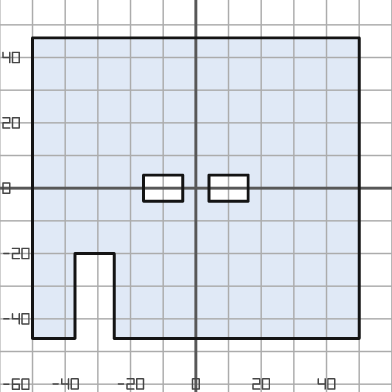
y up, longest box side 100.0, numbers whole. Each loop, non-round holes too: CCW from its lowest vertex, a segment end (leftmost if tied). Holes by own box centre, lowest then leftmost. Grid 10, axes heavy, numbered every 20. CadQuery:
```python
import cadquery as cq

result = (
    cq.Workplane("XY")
    .moveTo(-50.0, -46.0)
    .lineTo(-37.0, -46.0)
    .lineTo(-37.0, -20.0)
    .lineTo(-25.0, -20.0)
    .lineTo(-25.0, -46.0)
    .lineTo(50.0, -46.0)
    .lineTo(50.0, 46.0)
    .lineTo(-50.0, 46.0)
    .close()
    .moveTo(-16.0, -4.0)
    .lineTo(-4.0, -4.0)
    .lineTo(-4.0, 4.0)
    .lineTo(-16.0, 4.0)
    .close()
    .moveTo(4.0, -4.0)
    .lineTo(16.0, -4.0)
    .lineTo(16.0, 4.0)
    .lineTo(4.0, 4.0)
    .close()
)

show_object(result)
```